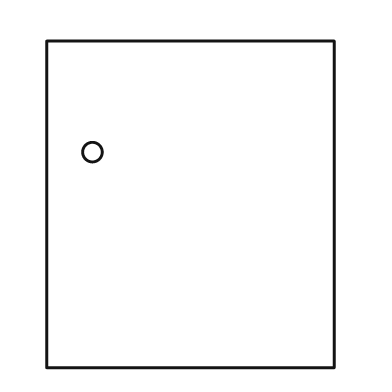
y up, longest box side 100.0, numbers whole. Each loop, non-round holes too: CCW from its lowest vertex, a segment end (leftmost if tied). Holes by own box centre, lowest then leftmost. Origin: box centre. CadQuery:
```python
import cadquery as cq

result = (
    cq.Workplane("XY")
    .moveTo(-44.0, -50.0)
    .lineTo(44.0, -50.0)
    .lineTo(44.0, 50.0)
    .lineTo(-44.0, 50.0)
    .close()
    .moveTo(-30.0, 16.0)
    .circle(3.0)
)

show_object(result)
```